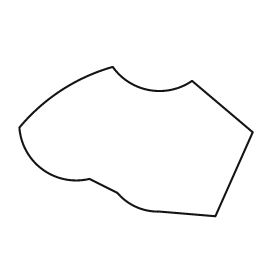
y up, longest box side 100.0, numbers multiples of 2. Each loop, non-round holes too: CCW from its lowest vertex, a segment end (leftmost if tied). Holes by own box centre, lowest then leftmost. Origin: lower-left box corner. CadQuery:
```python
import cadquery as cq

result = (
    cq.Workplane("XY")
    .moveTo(84.0, 0.0)
    .lineTo(100.0, 36.0)
    .lineTo(74.0, 58.0)
    .threePointArc((56.0, 54.0), (40.0, 64.0))
    .threePointArc((18.0, 54.0), (0.0, 38.0))
    .threePointArc((10.0, 20.0), (30.0, 16.0))
    .lineTo(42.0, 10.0)
    .threePointArc((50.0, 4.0), (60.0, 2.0))
    .close()
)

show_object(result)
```